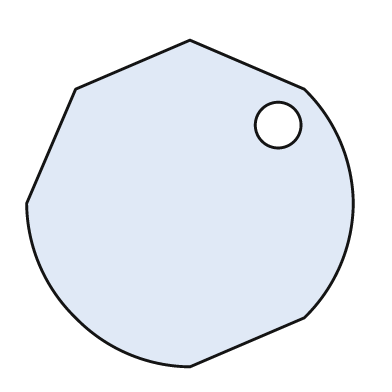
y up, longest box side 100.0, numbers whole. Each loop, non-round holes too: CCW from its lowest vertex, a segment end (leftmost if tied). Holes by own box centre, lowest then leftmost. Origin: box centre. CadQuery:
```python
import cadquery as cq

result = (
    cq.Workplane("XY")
    .moveTo(0.0, -50.0)
    .lineTo(35.0, -35.0)
    .threePointArc((46.0, -19.0), (50.0, 0.0))
    .threePointArc((46.0, 19.0), (35.0, 35.0))
    .lineTo(0.0, 50.0)
    .lineTo(-35.0, 35.0)
    .lineTo(-50.0, 0.0)
    .threePointArc((-46.0, -19.0), (-35.0, -35.0))
    .threePointArc((-19.0, -46.0), (0.0, -50.0))
    .close()
    .moveTo(27.0, 24.0)
    .circle(7.0)
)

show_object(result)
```